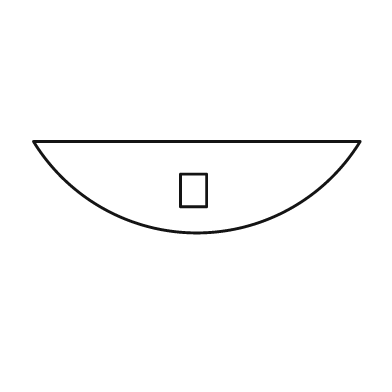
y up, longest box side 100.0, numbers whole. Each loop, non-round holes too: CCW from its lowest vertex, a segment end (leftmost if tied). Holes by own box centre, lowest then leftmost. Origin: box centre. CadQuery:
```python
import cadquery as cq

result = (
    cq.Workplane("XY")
    .moveTo(-50.0, 14.0)
    .threePointArc((0.0, -14.0), (50.0, 14.0))
    .close()
    .moveTo(-5.0, -6.0)
    .lineTo(3.0, -6.0)
    .lineTo(3.0, 4.0)
    .lineTo(-5.0, 4.0)
    .close()
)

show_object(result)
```